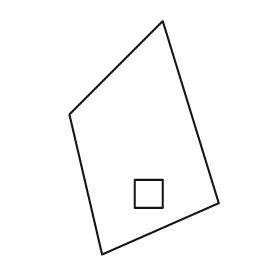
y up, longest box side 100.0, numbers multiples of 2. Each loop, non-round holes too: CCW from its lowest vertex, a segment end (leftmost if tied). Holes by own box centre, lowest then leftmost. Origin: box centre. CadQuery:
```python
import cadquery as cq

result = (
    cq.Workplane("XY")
    .moveTo(-18.0, -50.0)
    .lineTo(32.0, -28.0)
    .lineTo(8.0, 50.0)
    .lineTo(-32.0, 10.0)
    .close()
    .moveTo(-4.0, -30.0)
    .lineTo(8.0, -30.0)
    .lineTo(8.0, -18.0)
    .lineTo(-4.0, -18.0)
    .close()
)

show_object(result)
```